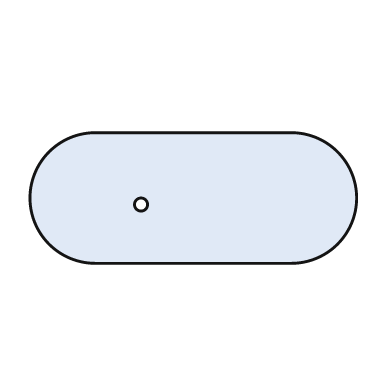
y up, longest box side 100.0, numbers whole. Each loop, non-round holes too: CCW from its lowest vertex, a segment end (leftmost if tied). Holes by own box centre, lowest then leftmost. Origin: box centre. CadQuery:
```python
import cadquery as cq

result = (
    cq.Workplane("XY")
    .moveTo(-30.0, -20.0)
    .lineTo(30.0, -20.0)
    .threePointArc((50.0, 0.0), (30.0, 20.0))
    .lineTo(-30.0, 20.0)
    .threePointArc((-50.0, 0.0), (-30.0, -20.0))
    .close()
    .moveTo(-16.0, -2.0)
    .circle(2.0)
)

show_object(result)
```